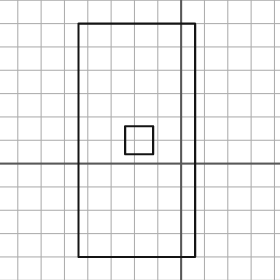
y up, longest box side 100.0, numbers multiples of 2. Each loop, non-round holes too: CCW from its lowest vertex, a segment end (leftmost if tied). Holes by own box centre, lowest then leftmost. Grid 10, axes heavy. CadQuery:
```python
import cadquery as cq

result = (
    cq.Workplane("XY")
    .moveTo(-44.0, -40.0)
    .lineTo(6.0, -40.0)
    .lineTo(6.0, 60.0)
    .lineTo(-44.0, 60.0)
    .close()
    .moveTo(-24.0, 4.0)
    .lineTo(-12.0, 4.0)
    .lineTo(-12.0, 16.0)
    .lineTo(-24.0, 16.0)
    .close()
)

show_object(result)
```